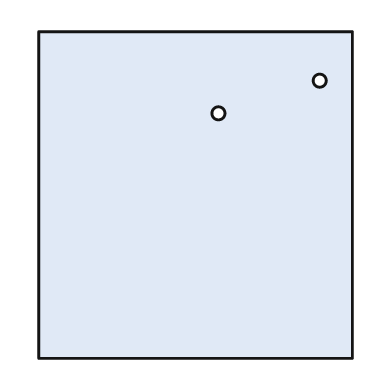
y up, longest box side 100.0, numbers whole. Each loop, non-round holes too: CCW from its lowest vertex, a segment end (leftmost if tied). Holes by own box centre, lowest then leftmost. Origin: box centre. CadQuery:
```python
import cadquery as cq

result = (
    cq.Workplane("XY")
    .moveTo(-48.0, -50.0)
    .lineTo(48.0, -50.0)
    .lineTo(48.0, 50.0)
    .lineTo(-48.0, 50.0)
    .close()
    .moveTo(7.0, 25.0)
    .circle(2.0)
    .moveTo(38.0, 35.0)
    .circle(2.0)
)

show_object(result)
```